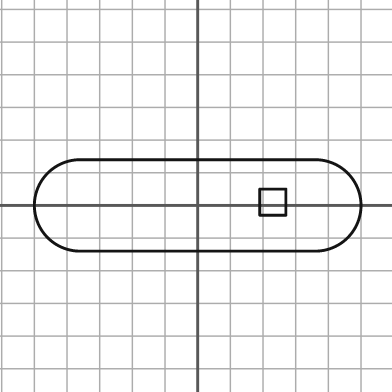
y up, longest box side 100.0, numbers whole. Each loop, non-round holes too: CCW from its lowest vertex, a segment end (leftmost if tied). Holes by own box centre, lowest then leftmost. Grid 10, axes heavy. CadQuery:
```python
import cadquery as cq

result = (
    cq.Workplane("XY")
    .moveTo(-36.0, -14.0)
    .lineTo(36.0, -14.0)
    .threePointArc((50.0, 0.0), (36.0, 14.0))
    .lineTo(-36.0, 14.0)
    .threePointArc((-50.0, 0.0), (-36.0, -14.0))
    .close()
    .moveTo(19.0, -3.0)
    .lineTo(27.0, -3.0)
    .lineTo(27.0, 5.0)
    .lineTo(19.0, 5.0)
    .close()
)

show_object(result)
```